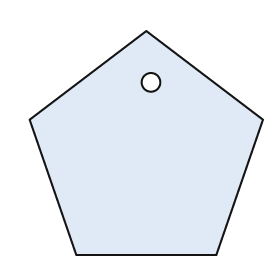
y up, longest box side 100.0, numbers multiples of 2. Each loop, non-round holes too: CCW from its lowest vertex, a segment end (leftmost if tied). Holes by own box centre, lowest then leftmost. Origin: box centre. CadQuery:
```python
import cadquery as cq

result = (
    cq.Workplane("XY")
    .moveTo(-30.0, -48.0)
    .lineTo(30.0, -48.0)
    .lineTo(50.0, 10.0)
    .lineTo(0.0, 48.0)
    .lineTo(-50.0, 10.0)
    .close()
    .moveTo(2.0, 26.0)
    .circle(4.0)
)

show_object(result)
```